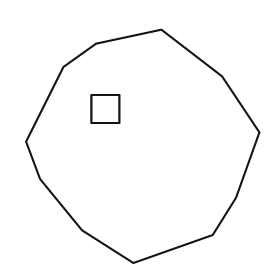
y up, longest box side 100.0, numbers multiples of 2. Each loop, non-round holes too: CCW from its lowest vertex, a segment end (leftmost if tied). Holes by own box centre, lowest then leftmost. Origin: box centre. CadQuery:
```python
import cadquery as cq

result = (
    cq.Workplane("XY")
    .moveTo(-4.0, -50.0)
    .lineTo(30.0, -38.0)
    .lineTo(40.0, -22.0)
    .lineTo(50.0, 6.0)
    .lineTo(34.0, 30.0)
    .lineTo(8.0, 50.0)
    .lineTo(-20.0, 44.0)
    .lineTo(-34.0, 34.0)
    .lineTo(-50.0, 2.0)
    .lineTo(-44.0, -14.0)
    .lineTo(-26.0, -36.0)
    .close()
    .moveTo(-22.0, 10.0)
    .lineTo(-10.0, 10.0)
    .lineTo(-10.0, 22.0)
    .lineTo(-22.0, 22.0)
    .close()
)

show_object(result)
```